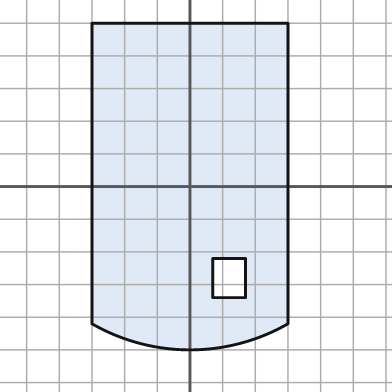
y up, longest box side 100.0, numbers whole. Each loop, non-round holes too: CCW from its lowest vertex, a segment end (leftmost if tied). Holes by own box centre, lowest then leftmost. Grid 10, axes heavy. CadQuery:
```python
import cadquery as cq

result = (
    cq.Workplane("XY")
    .moveTo(-30.0, -42.0)
    .threePointArc((0.0, -50.0), (30.0, -42.0))
    .lineTo(30.0, 50.0)
    .lineTo(-30.0, 50.0)
    .close()
    .moveTo(7.0, -34.0)
    .lineTo(17.0, -34.0)
    .lineTo(17.0, -22.0)
    .lineTo(7.0, -22.0)
    .close()
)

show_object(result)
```